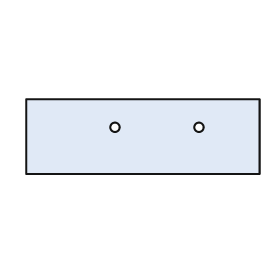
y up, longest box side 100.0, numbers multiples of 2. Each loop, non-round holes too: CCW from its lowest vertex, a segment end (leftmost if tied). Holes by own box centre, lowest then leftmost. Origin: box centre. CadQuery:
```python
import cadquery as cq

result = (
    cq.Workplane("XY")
    .moveTo(-50.0, -16.0)
    .lineTo(50.0, -16.0)
    .lineTo(50.0, 16.0)
    .lineTo(-50.0, 16.0)
    .close()
    .moveTo(-12.0, 4.0)
    .circle(2.0)
    .moveTo(24.0, 4.0)
    .circle(2.0)
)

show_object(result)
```